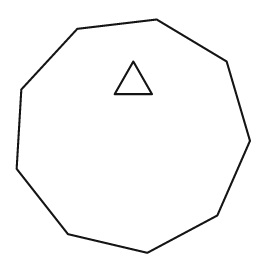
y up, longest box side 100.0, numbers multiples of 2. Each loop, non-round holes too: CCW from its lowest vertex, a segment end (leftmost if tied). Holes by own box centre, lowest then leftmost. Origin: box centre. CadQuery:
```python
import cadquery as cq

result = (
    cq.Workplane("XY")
    .moveTo(6.0, -50.0)
    .lineTo(36.0, -34.0)
    .lineTo(50.0, -2.0)
    .lineTo(40.0, 32.0)
    .lineTo(10.0, 50.0)
    .lineTo(-24.0, 46.0)
    .lineTo(-48.0, 20.0)
    .lineTo(-50.0, -14.0)
    .lineTo(-28.0, -42.0)
    .close()
    .moveTo(-8.0, 18.0)
    .lineTo(8.0, 18.0)
    .lineTo(0.0, 32.0)
    .close()
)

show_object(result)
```